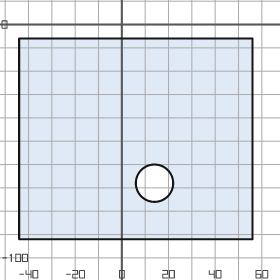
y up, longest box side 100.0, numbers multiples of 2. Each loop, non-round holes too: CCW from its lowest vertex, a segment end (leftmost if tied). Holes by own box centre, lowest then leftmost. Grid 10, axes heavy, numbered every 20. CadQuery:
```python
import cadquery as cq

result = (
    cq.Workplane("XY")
    .moveTo(-44.0, -92.0)
    .lineTo(56.0, -92.0)
    .lineTo(56.0, -6.0)
    .lineTo(-44.0, -6.0)
    .close()
    .moveTo(14.0, -68.0)
    .circle(8.0)
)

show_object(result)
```